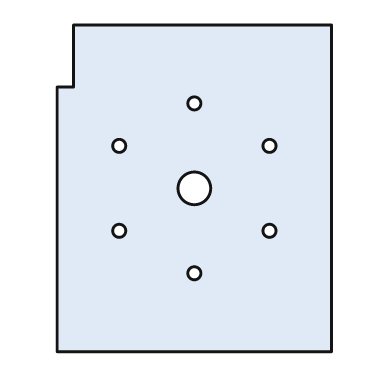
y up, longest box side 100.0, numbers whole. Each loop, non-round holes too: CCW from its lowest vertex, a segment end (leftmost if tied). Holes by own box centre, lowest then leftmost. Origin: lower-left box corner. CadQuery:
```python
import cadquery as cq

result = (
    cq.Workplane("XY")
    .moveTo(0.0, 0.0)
    .lineTo(84.0, 0.0)
    .lineTo(84.0, 100.0)
    .lineTo(5.0, 100.0)
    .lineTo(5.0, 81.0)
    .lineTo(0.0, 81.0)
    .close()
    .moveTo(42.0, 24.0)
    .circle(2.0)
    .moveTo(19.0, 37.0)
    .circle(2.0)
    .moveTo(65.0, 37.0)
    .circle(2.0)
    .moveTo(42.0, 50.0)
    .circle(5.0)
    .moveTo(19.0, 63.0)
    .circle(2.0)
    .moveTo(65.0, 63.0)
    .circle(2.0)
    .moveTo(42.0, 76.0)
    .circle(2.0)
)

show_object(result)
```